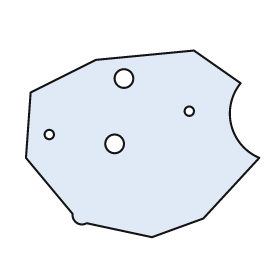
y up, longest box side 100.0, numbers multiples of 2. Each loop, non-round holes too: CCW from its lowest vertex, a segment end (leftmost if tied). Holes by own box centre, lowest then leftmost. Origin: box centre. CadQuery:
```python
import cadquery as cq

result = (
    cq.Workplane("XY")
    .moveTo(4.0, -40.0)
    .lineTo(26.0, -32.0)
    .lineTo(50.0, -6.0)
    .threePointArc((38.0, 8.0), (42.0, 26.0))
    .lineTo(22.0, 40.0)
    .lineTo(-20.0, 36.0)
    .lineTo(-48.0, 22.0)
    .lineTo(-50.0, -6.0)
    .lineTo(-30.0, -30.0)
    .threePointArc((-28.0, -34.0), (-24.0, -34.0))
    .close()
    .moveTo(-12.0, 0.0)
    .circle(4.0)
    .moveTo(-40.0, 4.0)
    .circle(2.0)
    .moveTo(20.0, 14.0)
    .circle(2.0)
    .moveTo(-8.0, 28.0)
    .circle(4.0)
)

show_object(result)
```